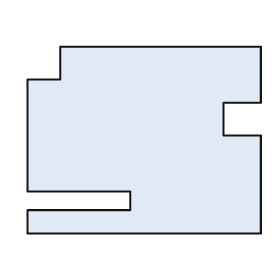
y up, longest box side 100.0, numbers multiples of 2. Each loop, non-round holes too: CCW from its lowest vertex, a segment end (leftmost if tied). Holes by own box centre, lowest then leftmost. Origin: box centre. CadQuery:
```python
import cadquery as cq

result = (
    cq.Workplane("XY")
    .moveTo(-50.0, -40.0)
    .lineTo(50.0, -40.0)
    .lineTo(50.0, 2.0)
    .lineTo(34.0, 2.0)
    .lineTo(34.0, 16.0)
    .lineTo(50.0, 16.0)
    .lineTo(50.0, 40.0)
    .lineTo(-36.0, 40.0)
    .lineTo(-36.0, 26.0)
    .lineTo(-50.0, 26.0)
    .lineTo(-50.0, -22.0)
    .lineTo(-6.0, -22.0)
    .lineTo(-6.0, -30.0)
    .lineTo(-50.0, -30.0)
    .close()
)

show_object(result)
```